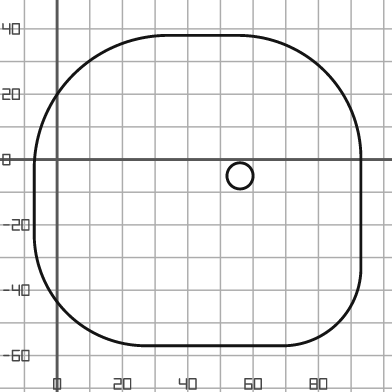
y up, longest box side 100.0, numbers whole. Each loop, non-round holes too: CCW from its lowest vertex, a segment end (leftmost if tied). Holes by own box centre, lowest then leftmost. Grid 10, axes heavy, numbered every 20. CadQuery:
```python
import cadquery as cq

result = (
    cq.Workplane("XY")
    .moveTo(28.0, -57.0)
    .lineTo(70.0, -57.0)
    .threePointArc((86.0, -50.0), (93.0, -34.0))
    .lineTo(93.0, 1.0)
    .threePointArc((82.0, 27.0), (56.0, 38.0))
    .lineTo(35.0, 38.0)
    .threePointArc((5.0, 26.0), (-7.0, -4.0))
    .lineTo(-7.0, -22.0)
    .threePointArc((3.0, -47.0), (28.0, -57.0))
    .close()
    .moveTo(56.0, -5.0)
    .circle(4.0)
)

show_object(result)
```